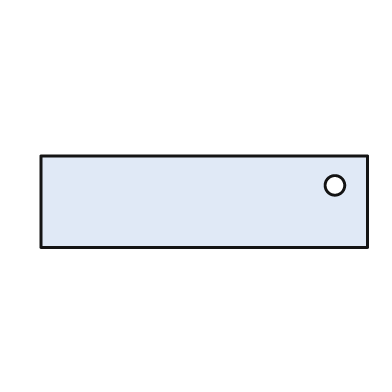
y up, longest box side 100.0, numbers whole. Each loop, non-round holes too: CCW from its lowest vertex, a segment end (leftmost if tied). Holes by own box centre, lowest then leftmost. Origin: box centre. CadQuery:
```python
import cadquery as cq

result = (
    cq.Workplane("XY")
    .moveTo(-50.0, -14.0)
    .lineTo(50.0, -14.0)
    .lineTo(50.0, 14.0)
    .lineTo(-50.0, 14.0)
    .close()
    .moveTo(40.0, 5.0)
    .circle(3.0)
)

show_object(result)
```